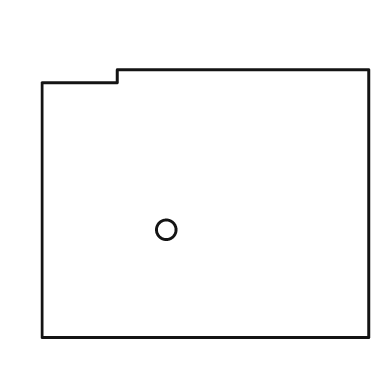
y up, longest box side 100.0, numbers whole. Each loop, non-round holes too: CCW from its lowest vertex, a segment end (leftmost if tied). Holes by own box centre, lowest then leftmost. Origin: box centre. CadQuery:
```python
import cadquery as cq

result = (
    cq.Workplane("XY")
    .moveTo(-50.0, -41.0)
    .lineTo(50.0, -41.0)
    .lineTo(50.0, 41.0)
    .lineTo(-27.0, 41.0)
    .lineTo(-27.0, 37.0)
    .lineTo(-50.0, 37.0)
    .close()
    .moveTo(-12.0, -8.0)
    .circle(3.0)
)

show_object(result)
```